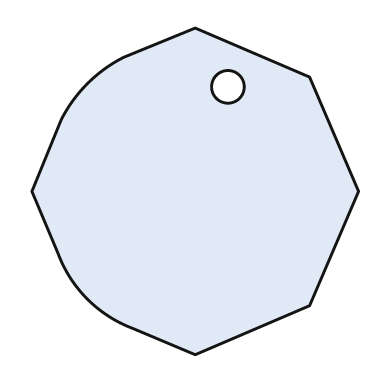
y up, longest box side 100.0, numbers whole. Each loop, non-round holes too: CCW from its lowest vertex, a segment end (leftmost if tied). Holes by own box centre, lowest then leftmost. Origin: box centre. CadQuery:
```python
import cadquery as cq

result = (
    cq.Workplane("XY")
    .moveTo(0.0, -50.0)
    .lineTo(35.0, -35.0)
    .lineTo(50.0, 0.0)
    .lineTo(35.0, 35.0)
    .lineTo(0.0, 50.0)
    .lineTo(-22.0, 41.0)
    .threePointArc((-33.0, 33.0), (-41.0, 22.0))
    .lineTo(-50.0, 0.0)
    .lineTo(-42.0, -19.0)
    .threePointArc((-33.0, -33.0), (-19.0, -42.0))
    .close()
    .moveTo(10.0, 32.0)
    .circle(5.0)
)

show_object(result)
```